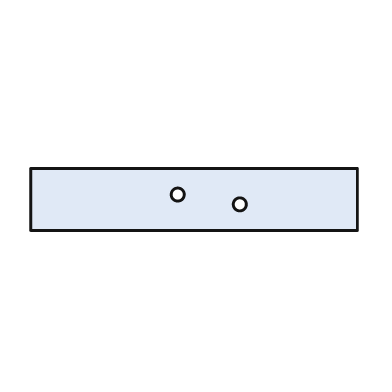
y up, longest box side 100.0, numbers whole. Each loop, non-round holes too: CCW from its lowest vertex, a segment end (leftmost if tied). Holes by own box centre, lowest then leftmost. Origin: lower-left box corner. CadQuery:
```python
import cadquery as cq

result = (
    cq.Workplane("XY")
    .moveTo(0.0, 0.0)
    .lineTo(100.0, 0.0)
    .lineTo(100.0, 19.0)
    .lineTo(0.0, 19.0)
    .close()
    .moveTo(64.0, 8.0)
    .circle(2.0)
    .moveTo(45.0, 11.0)
    .circle(2.0)
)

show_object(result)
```